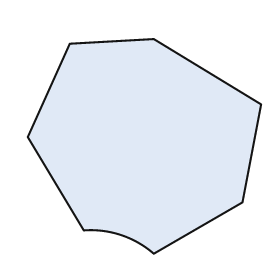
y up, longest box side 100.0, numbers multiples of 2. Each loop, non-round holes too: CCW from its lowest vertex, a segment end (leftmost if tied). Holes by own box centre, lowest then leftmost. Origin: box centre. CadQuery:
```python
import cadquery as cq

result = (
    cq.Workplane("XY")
    .moveTo(4.0, -46.0)
    .lineTo(42.0, -24.0)
    .lineTo(50.0, 18.0)
    .lineTo(4.0, 46.0)
    .lineTo(-32.0, 44.0)
    .lineTo(-50.0, 4.0)
    .lineTo(-26.0, -36.0)
    .threePointArc((-10.0, -38.0), (4.0, -46.0))
    .close()
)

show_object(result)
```